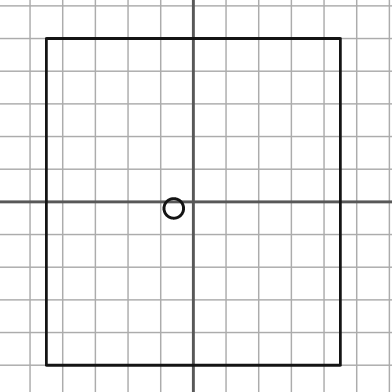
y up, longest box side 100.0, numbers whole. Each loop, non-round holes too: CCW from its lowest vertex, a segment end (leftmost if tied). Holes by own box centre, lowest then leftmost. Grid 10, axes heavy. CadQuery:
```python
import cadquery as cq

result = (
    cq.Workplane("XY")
    .moveTo(-45.0, -50.0)
    .lineTo(45.0, -50.0)
    .lineTo(45.0, 50.0)
    .lineTo(-45.0, 50.0)
    .close()
    .moveTo(-6.0, -2.0)
    .circle(3.0)
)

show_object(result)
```